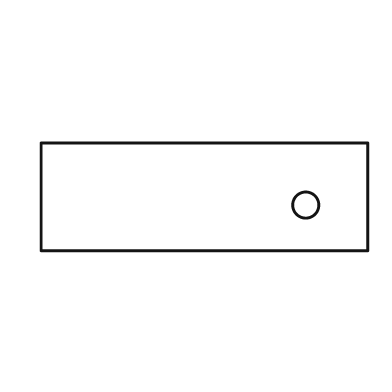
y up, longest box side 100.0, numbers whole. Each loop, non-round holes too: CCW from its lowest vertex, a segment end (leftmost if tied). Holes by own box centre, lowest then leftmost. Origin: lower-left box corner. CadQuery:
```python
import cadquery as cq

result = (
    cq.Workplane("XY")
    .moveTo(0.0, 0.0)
    .lineTo(100.0, 0.0)
    .lineTo(100.0, 33.0)
    .lineTo(0.0, 33.0)
    .close()
    .moveTo(81.0, 14.0)
    .circle(4.0)
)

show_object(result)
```